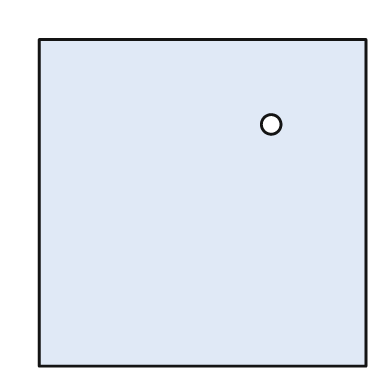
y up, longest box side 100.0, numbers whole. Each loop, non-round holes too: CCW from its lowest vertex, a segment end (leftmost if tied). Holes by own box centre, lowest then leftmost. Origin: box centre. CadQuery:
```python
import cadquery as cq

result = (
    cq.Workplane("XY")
    .moveTo(-50.0, -50.0)
    .lineTo(50.0, -50.0)
    .lineTo(50.0, 50.0)
    .lineTo(-50.0, 50.0)
    .close()
    .moveTo(21.0, 24.0)
    .circle(3.0)
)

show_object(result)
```